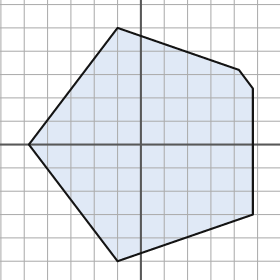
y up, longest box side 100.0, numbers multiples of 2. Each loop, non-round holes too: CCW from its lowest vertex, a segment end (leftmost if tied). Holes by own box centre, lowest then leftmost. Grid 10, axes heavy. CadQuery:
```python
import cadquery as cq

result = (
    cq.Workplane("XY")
    .moveTo(-10.0, -50.0)
    .lineTo(48.0, -30.0)
    .lineTo(48.0, 24.0)
    .lineTo(42.0, 32.0)
    .lineTo(-10.0, 50.0)
    .lineTo(-48.0, 0.0)
    .close()
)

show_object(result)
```